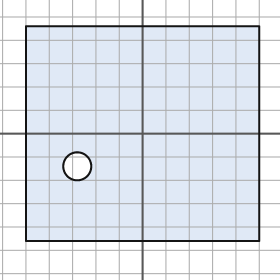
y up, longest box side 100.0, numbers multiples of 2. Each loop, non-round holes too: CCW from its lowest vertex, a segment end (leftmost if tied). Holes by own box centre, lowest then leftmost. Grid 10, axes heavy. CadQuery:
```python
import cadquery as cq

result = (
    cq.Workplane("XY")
    .moveTo(-50.0, -46.0)
    .lineTo(50.0, -46.0)
    .lineTo(50.0, 46.0)
    .lineTo(-50.0, 46.0)
    .close()
    .moveTo(-28.0, -14.0)
    .circle(6.0)
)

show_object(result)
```